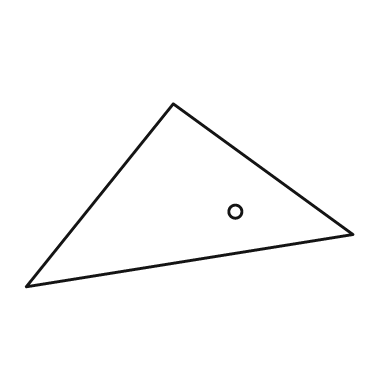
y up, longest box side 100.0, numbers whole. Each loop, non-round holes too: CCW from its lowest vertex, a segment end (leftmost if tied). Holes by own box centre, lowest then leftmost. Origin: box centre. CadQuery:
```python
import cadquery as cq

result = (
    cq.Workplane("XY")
    .moveTo(-50.0, -28.0)
    .lineTo(50.0, -12.0)
    .lineTo(-5.0, 28.0)
    .close()
    .moveTo(14.0, -5.0)
    .circle(2.0)
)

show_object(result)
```